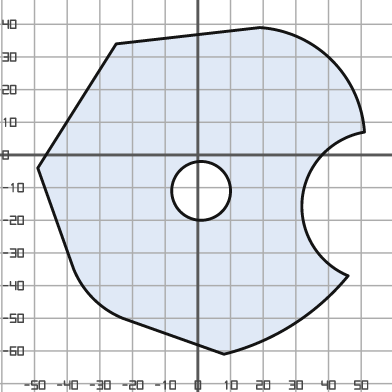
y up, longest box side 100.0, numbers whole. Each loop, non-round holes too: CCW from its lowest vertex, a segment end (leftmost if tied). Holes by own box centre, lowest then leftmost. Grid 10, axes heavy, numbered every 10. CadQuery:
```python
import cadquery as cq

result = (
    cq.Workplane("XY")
    .moveTo(8.0, -61.0)
    .threePointArc((29.0, -52.0), (46.0, -37.0))
    .threePointArc((32.0, -13.0), (51.0, 7.0))
    .threePointArc((41.0, 29.0), (19.0, 39.0))
    .lineTo(-25.0, 34.0)
    .lineTo(-49.0, -4.0)
    .lineTo(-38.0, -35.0)
    .threePointArc((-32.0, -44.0), (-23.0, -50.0))
    .close()
    .moveTo(1.0, -11.0)
    .circle(9.0)
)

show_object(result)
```